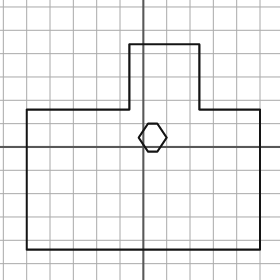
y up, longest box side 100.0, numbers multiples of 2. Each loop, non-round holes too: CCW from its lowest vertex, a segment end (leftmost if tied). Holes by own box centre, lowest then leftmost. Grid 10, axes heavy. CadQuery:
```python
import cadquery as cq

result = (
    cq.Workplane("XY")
    .moveTo(-50.0, -44.0)
    .lineTo(50.0, -44.0)
    .lineTo(50.0, 16.0)
    .lineTo(24.0, 16.0)
    .lineTo(24.0, 44.0)
    .lineTo(-6.0, 44.0)
    .lineTo(-6.0, 16.0)
    .lineTo(-50.0, 16.0)
    .close()
    .moveTo(2.0, -2.0)
    .lineTo(6.0, -2.0)
    .lineTo(10.0, 4.0)
    .lineTo(6.0, 10.0)
    .lineTo(2.0, 10.0)
    .lineTo(-2.0, 4.0)
    .close()
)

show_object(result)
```